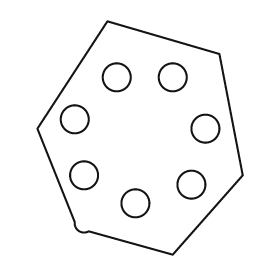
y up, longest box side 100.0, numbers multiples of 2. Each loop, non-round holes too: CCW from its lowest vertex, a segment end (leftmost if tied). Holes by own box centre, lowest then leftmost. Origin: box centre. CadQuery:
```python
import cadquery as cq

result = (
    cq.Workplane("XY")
    .moveTo(14.0, -50.0)
    .lineTo(44.0, -16.0)
    .lineTo(34.0, 36.0)
    .lineTo(-14.0, 50.0)
    .lineTo(-44.0, 4.0)
    .lineTo(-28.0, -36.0)
    .threePointArc((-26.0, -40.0), (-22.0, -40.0))
    .close()
    .moveTo(-2.0, -28.0)
    .circle(6.0)
    .moveTo(22.0, -20.0)
    .circle(6.0)
    .moveTo(-24.0, -16.0)
    .circle(6.0)
    .moveTo(28.0, 4.0)
    .circle(6.0)
    .moveTo(-28.0, 8.0)
    .circle(6.0)
    .moveTo(-10.0, 26.0)
    .circle(6.0)
    .moveTo(14.0, 26.0)
    .circle(6.0)
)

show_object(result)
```